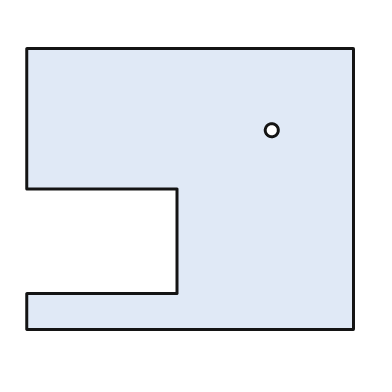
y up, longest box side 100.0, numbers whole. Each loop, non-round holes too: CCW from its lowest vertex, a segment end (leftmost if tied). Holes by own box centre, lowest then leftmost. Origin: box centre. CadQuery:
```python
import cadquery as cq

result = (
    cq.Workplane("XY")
    .moveTo(-50.0, -43.0)
    .lineTo(50.0, -43.0)
    .lineTo(50.0, 43.0)
    .lineTo(-50.0, 43.0)
    .lineTo(-50.0, 0.0)
    .lineTo(-4.0, 0.0)
    .lineTo(-4.0, -32.0)
    .lineTo(-50.0, -32.0)
    .close()
    .moveTo(25.0, 18.0)
    .circle(2.0)
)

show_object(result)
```